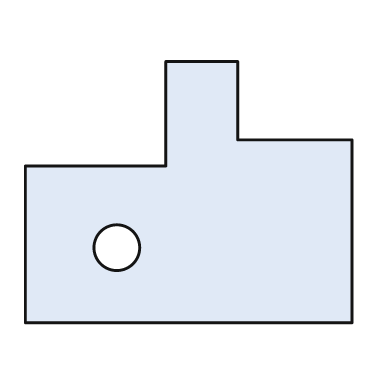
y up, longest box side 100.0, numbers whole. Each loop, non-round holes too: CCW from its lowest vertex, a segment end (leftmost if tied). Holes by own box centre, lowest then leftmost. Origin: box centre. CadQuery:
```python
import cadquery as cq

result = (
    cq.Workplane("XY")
    .moveTo(-50.0, -40.0)
    .lineTo(50.0, -40.0)
    .lineTo(50.0, 16.0)
    .lineTo(15.0, 16.0)
    .lineTo(15.0, 40.0)
    .lineTo(-7.0, 40.0)
    .lineTo(-7.0, 8.0)
    .lineTo(-50.0, 8.0)
    .close()
    .moveTo(-22.0, -17.0)
    .circle(7.0)
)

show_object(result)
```